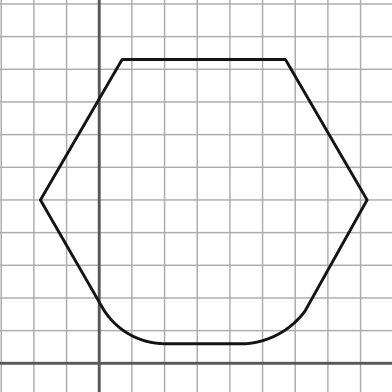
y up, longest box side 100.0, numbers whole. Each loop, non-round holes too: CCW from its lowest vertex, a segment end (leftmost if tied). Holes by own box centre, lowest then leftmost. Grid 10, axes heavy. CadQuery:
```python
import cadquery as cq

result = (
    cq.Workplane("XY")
    .moveTo(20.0, 6.0)
    .lineTo(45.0, 6.0)
    .threePointArc((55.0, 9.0), (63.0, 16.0))
    .lineTo(82.0, 50.0)
    .lineTo(57.0, 93.0)
    .lineTo(7.0, 93.0)
    .lineTo(-18.0, 50.0)
    .lineTo(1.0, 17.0)
    .threePointArc((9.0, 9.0), (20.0, 6.0))
    .close()
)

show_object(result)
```